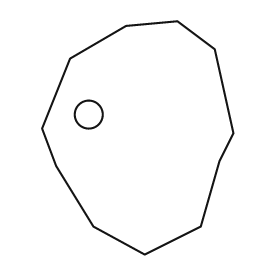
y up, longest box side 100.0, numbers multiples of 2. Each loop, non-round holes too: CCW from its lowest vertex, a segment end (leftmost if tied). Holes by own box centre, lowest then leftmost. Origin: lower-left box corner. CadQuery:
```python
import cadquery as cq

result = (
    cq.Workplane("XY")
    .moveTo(44.0, 0.0)
    .lineTo(68.0, 12.0)
    .lineTo(76.0, 40.0)
    .lineTo(82.0, 52.0)
    .lineTo(74.0, 88.0)
    .lineTo(58.0, 100.0)
    .lineTo(36.0, 98.0)
    .lineTo(12.0, 84.0)
    .lineTo(0.0, 54.0)
    .lineTo(6.0, 38.0)
    .lineTo(22.0, 12.0)
    .close()
    .moveTo(20.0, 60.0)
    .circle(6.0)
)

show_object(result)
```